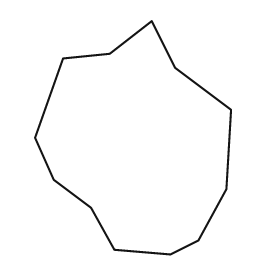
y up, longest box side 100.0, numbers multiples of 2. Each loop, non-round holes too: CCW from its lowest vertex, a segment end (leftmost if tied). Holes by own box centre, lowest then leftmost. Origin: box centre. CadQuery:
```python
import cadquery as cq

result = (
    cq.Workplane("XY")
    .moveTo(16.0, -50.0)
    .lineTo(28.0, -44.0)
    .lineTo(40.0, -22.0)
    .lineTo(42.0, 12.0)
    .lineTo(18.0, 30.0)
    .lineTo(8.0, 50.0)
    .lineTo(-10.0, 36.0)
    .lineTo(-30.0, 34.0)
    .lineTo(-42.0, 0.0)
    .lineTo(-34.0, -18.0)
    .lineTo(-18.0, -30.0)
    .lineTo(-8.0, -48.0)
    .close()
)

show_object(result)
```